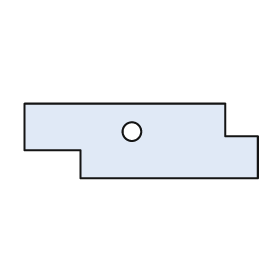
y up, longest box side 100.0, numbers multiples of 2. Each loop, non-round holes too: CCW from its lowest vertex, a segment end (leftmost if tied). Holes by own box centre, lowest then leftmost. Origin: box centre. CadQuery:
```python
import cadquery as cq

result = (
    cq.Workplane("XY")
    .moveTo(-26.0, -16.0)
    .lineTo(50.0, -16.0)
    .lineTo(50.0, 2.0)
    .lineTo(36.0, 2.0)
    .lineTo(36.0, 16.0)
    .lineTo(-50.0, 16.0)
    .lineTo(-50.0, -4.0)
    .lineTo(-26.0, -4.0)
    .close()
    .moveTo(-4.0, 4.0)
    .circle(4.0)
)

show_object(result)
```